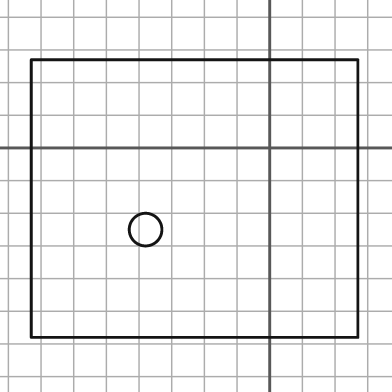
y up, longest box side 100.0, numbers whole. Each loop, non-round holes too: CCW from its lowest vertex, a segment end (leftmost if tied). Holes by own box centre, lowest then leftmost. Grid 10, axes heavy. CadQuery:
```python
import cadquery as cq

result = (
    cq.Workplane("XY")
    .moveTo(-73.0, -58.0)
    .lineTo(27.0, -58.0)
    .lineTo(27.0, 27.0)
    .lineTo(-73.0, 27.0)
    .close()
    .moveTo(-38.0, -25.0)
    .circle(5.0)
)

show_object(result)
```